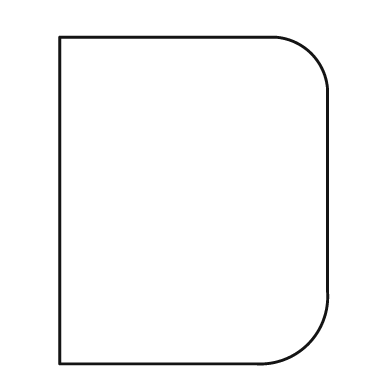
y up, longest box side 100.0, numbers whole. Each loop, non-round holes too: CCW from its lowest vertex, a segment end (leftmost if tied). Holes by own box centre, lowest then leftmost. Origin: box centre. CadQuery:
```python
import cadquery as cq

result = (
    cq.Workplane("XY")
    .moveTo(-41.0, -50.0)
    .lineTo(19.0, -50.0)
    .threePointArc((35.0, -44.0), (41.0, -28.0))
    .lineTo(41.0, 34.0)
    .threePointArc((36.0, 45.0), (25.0, 50.0))
    .lineTo(-41.0, 50.0)
    .close()
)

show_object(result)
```